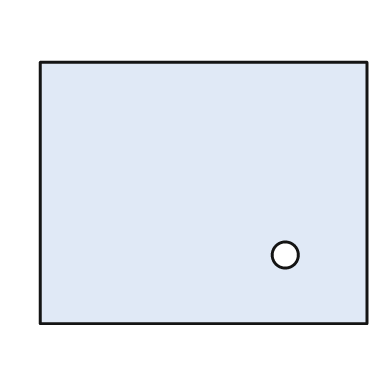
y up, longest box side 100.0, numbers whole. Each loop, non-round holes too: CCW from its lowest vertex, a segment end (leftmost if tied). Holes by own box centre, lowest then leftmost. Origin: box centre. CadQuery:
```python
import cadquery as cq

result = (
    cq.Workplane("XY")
    .moveTo(-50.0, -40.0)
    .lineTo(50.0, -40.0)
    .lineTo(50.0, 40.0)
    .lineTo(-50.0, 40.0)
    .close()
    .moveTo(25.0, -19.0)
    .circle(4.0)
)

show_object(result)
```